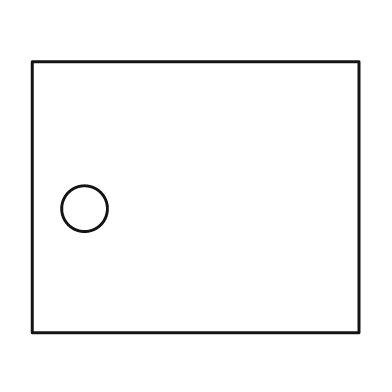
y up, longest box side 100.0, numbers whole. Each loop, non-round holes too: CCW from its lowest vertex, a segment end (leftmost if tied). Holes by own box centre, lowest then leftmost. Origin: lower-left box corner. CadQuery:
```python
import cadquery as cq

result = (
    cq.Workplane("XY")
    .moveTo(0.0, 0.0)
    .lineTo(100.0, 0.0)
    .lineTo(100.0, 83.0)
    .lineTo(0.0, 83.0)
    .close()
    .moveTo(16.0, 38.0)
    .circle(7.0)
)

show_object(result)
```